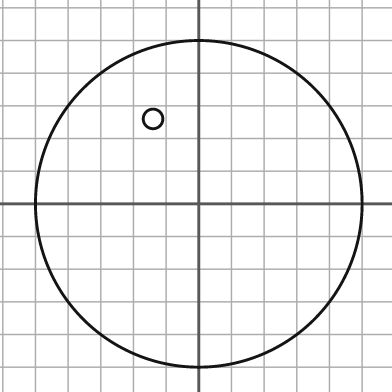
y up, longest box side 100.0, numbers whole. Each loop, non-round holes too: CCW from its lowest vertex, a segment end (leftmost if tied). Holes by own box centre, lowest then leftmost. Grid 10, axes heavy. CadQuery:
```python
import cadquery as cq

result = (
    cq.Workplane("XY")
    .moveTo(0.0, 0.0)
    .circle(50.0)
    .moveTo(-14.0, 26.0)
    .circle(3.0)
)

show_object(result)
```